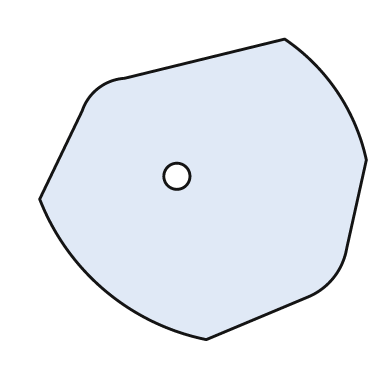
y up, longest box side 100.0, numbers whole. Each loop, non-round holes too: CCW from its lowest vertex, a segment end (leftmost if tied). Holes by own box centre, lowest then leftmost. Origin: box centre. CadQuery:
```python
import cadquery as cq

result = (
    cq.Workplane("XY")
    .moveTo(1.0, -46.0)
    .lineTo(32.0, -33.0)
    .threePointArc((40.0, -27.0), (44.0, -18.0))
    .lineTo(50.0, 9.0)
    .threePointArc((41.0, 30.0), (25.0, 46.0))
    .lineTo(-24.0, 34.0)
    .threePointArc((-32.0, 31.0), (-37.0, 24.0))
    .lineTo(-50.0, -3.0)
    .threePointArc((-30.0, -31.0), (1.0, -46.0))
    .close()
    .moveTo(-8.0, 4.0)
    .circle(4.0)
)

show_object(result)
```